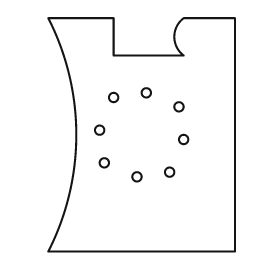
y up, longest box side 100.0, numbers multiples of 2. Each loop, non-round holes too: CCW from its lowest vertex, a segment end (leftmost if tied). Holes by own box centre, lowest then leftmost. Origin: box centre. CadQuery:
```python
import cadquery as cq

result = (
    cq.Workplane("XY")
    .moveTo(-40.0, -50.0)
    .lineTo(40.0, -50.0)
    .lineTo(40.0, 50.0)
    .lineTo(18.0, 50.0)
    .threePointArc((14.0, 42.0), (18.0, 34.0))
    .lineTo(-12.0, 34.0)
    .lineTo(-12.0, 50.0)
    .lineTo(-40.0, 50.0)
    .threePointArc((-28.0, 0.0), (-40.0, -50.0))
    .close()
    .moveTo(-2.0, -18.0)
    .circle(2.0)
    .moveTo(12.0, -16.0)
    .circle(2.0)
    .moveTo(-16.0, -12.0)
    .circle(2.0)
    .moveTo(18.0, -2.0)
    .circle(2.0)
    .moveTo(-18.0, 2.0)
    .circle(2.0)
    .moveTo(16.0, 12.0)
    .circle(2.0)
    .moveTo(-12.0, 16.0)
    .circle(2.0)
    .moveTo(2.0, 18.0)
    .circle(2.0)
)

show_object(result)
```